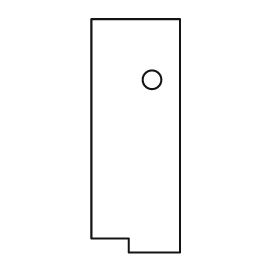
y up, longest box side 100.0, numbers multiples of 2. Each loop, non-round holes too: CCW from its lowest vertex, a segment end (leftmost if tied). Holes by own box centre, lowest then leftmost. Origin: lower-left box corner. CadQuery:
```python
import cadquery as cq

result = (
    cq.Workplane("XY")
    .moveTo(16.0, 0.0)
    .lineTo(38.0, 0.0)
    .lineTo(38.0, 100.0)
    .lineTo(0.0, 100.0)
    .lineTo(0.0, 6.0)
    .lineTo(16.0, 6.0)
    .close()
    .moveTo(26.0, 74.0)
    .circle(4.0)
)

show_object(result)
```